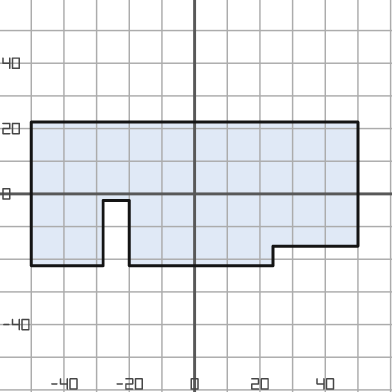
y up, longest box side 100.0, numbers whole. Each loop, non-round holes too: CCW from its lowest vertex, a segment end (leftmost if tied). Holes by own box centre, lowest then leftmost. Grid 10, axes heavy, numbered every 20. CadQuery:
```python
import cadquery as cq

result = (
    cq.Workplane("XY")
    .moveTo(-50.0, -22.0)
    .lineTo(-28.0, -22.0)
    .lineTo(-28.0, -2.0)
    .lineTo(-20.0, -2.0)
    .lineTo(-20.0, -22.0)
    .lineTo(24.0, -22.0)
    .lineTo(24.0, -16.0)
    .lineTo(50.0, -16.0)
    .lineTo(50.0, 22.0)
    .lineTo(-50.0, 22.0)
    .close()
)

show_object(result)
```